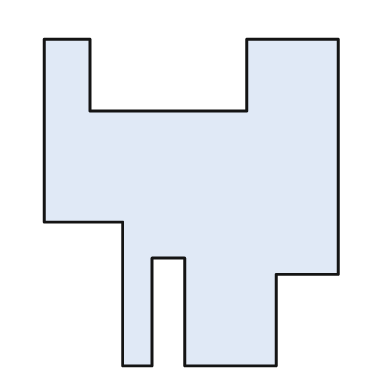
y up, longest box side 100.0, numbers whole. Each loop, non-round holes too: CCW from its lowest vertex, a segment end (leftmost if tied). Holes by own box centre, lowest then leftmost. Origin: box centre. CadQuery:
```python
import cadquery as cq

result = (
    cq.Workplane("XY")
    .moveTo(-21.0, -50.0)
    .lineTo(-12.0, -50.0)
    .lineTo(-12.0, -17.0)
    .lineTo(-2.0, -17.0)
    .lineTo(-2.0, -50.0)
    .lineTo(26.0, -50.0)
    .lineTo(26.0, -22.0)
    .lineTo(45.0, -22.0)
    .lineTo(45.0, 50.0)
    .lineTo(17.0, 50.0)
    .lineTo(17.0, 28.0)
    .lineTo(-31.0, 28.0)
    .lineTo(-31.0, 50.0)
    .lineTo(-45.0, 50.0)
    .lineTo(-45.0, -6.0)
    .lineTo(-21.0, -6.0)
    .close()
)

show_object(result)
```